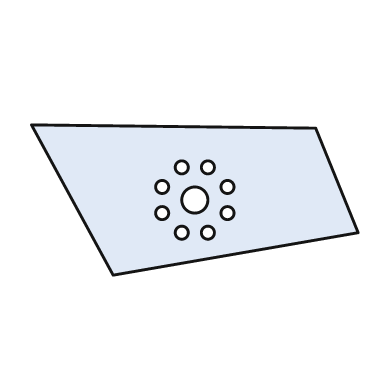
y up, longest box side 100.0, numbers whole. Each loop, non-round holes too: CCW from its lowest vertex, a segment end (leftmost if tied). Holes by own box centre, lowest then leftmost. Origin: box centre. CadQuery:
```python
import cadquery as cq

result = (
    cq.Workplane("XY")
    .moveTo(-25.0, -23.0)
    .lineTo(50.0, -10.0)
    .lineTo(37.0, 22.0)
    .lineTo(-50.0, 23.0)
    .close()
    .moveTo(-4.0, -10.0)
    .circle(2.0)
    .moveTo(4.0, -10.0)
    .circle(2.0)
    .moveTo(-10.0, -4.0)
    .circle(2.0)
    .moveTo(10.0, -4.0)
    .circle(2.0)
    .moveTo(0.0, 0.0)
    .circle(4.0)
    .moveTo(-10.0, 4.0)
    .circle(2.0)
    .moveTo(10.0, 4.0)
    .circle(2.0)
    .moveTo(-4.0, 10.0)
    .circle(2.0)
    .moveTo(4.0, 10.0)
    .circle(2.0)
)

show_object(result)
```